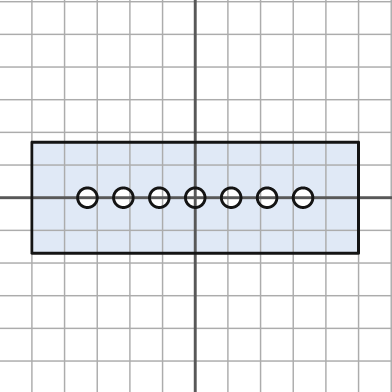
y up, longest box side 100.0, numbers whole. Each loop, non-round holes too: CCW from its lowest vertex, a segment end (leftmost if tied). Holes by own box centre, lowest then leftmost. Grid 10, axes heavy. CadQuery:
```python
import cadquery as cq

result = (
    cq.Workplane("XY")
    .moveTo(-50.0, -17.0)
    .lineTo(50.0, -17.0)
    .lineTo(50.0, 17.0)
    .lineTo(-50.0, 17.0)
    .close()
    .moveTo(-33.0, 0.0)
    .circle(3.0)
    .moveTo(-22.0, 0.0)
    .circle(3.0)
    .moveTo(-11.0, 0.0)
    .circle(3.0)
    .moveTo(0.0, 0.0)
    .circle(3.0)
    .moveTo(11.0, 0.0)
    .circle(3.0)
    .moveTo(22.0, 0.0)
    .circle(3.0)
    .moveTo(33.0, 0.0)
    .circle(3.0)
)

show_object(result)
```